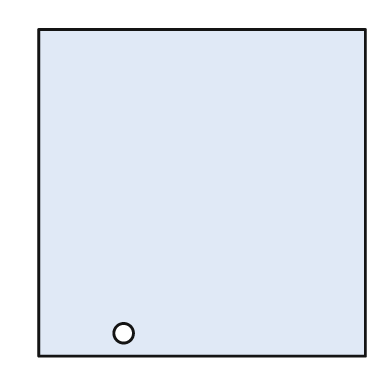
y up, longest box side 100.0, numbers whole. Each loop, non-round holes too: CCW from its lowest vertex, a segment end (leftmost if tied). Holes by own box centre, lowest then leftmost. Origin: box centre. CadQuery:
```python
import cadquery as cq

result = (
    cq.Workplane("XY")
    .moveTo(-50.0, -50.0)
    .lineTo(50.0, -50.0)
    .lineTo(50.0, 50.0)
    .lineTo(-50.0, 50.0)
    .close()
    .moveTo(-24.0, -43.0)
    .circle(3.0)
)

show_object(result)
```